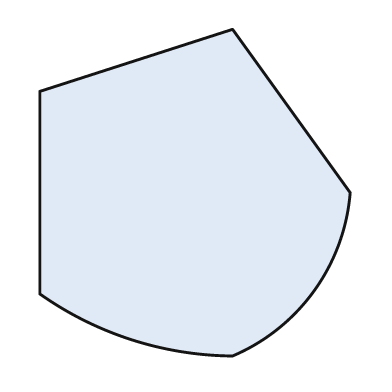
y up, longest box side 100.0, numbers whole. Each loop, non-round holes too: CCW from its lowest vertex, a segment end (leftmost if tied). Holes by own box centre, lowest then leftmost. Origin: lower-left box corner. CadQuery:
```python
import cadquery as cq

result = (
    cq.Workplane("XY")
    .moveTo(59.0, 0.0)
    .threePointArc((84.0, 20.0), (95.0, 50.0))
    .lineTo(59.0, 100.0)
    .lineTo(0.0, 81.0)
    .lineTo(0.0, 19.0)
    .threePointArc((28.0, 5.0), (59.0, 0.0))
    .close()
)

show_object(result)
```